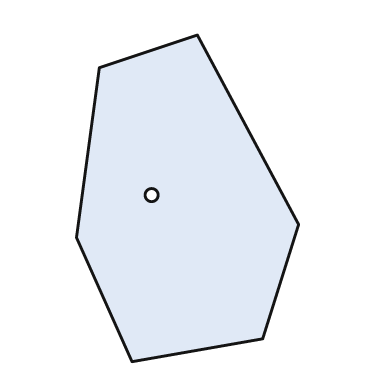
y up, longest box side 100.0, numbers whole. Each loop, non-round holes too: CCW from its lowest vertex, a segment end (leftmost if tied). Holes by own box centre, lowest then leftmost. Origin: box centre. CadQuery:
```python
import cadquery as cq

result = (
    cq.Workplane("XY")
    .moveTo(-17.0, -50.0)
    .lineTo(23.0, -43.0)
    .lineTo(34.0, -8.0)
    .lineTo(3.0, 50.0)
    .lineTo(-27.0, 40.0)
    .lineTo(-34.0, -12.0)
    .close()
    .moveTo(-11.0, 1.0)
    .circle(2.0)
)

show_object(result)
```